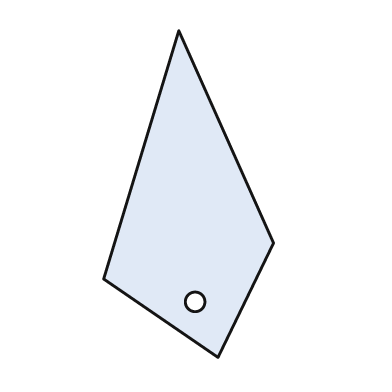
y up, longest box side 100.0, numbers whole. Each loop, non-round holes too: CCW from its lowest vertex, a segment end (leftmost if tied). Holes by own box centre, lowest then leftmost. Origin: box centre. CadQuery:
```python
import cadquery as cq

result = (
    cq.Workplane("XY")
    .moveTo(9.0, -50.0)
    .lineTo(26.0, -15.0)
    .lineTo(-3.0, 50.0)
    .lineTo(-26.0, -26.0)
    .close()
    .moveTo(2.0, -33.0)
    .circle(3.0)
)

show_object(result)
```